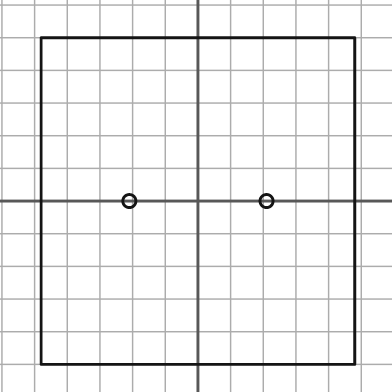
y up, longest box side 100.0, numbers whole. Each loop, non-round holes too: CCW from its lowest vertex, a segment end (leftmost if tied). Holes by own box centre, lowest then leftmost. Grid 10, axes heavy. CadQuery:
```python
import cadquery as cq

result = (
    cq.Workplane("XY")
    .moveTo(-48.0, -50.0)
    .lineTo(48.0, -50.0)
    .lineTo(48.0, 50.0)
    .lineTo(-48.0, 50.0)
    .close()
    .moveTo(-21.0, 0.0)
    .circle(2.0)
    .moveTo(21.0, 0.0)
    .circle(2.0)
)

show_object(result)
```